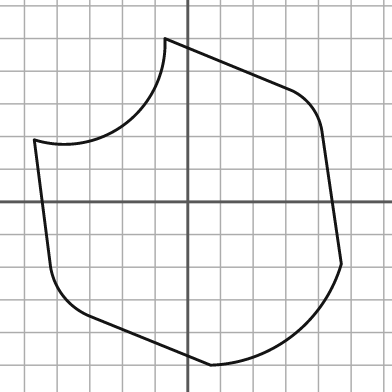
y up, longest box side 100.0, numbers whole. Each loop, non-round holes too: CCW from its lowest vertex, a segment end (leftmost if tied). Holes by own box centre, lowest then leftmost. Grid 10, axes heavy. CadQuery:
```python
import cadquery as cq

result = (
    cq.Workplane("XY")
    .moveTo(7.0, -50.0)
    .threePointArc((32.0, -41.0), (47.0, -19.0))
    .lineTo(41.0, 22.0)
    .threePointArc((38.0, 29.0), (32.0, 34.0))
    .lineTo(-7.0, 50.0)
    .threePointArc((-19.0, 24.0), (-47.0, 19.0))
    .lineTo(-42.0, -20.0)
    .threePointArc((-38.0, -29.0), (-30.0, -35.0))
    .close()
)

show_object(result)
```